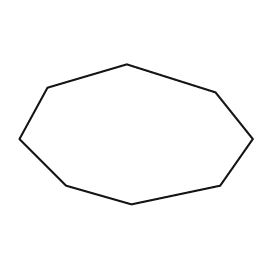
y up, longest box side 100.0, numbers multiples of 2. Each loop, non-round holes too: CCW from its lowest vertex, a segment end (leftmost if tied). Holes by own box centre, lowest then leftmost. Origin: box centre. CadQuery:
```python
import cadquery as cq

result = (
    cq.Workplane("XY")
    .moveTo(-2.0, -30.0)
    .lineTo(36.0, -22.0)
    .lineTo(50.0, -2.0)
    .lineTo(34.0, 18.0)
    .lineTo(-4.0, 30.0)
    .lineTo(-38.0, 20.0)
    .lineTo(-50.0, -2.0)
    .lineTo(-30.0, -22.0)
    .close()
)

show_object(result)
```